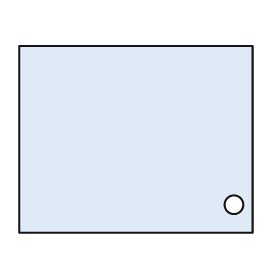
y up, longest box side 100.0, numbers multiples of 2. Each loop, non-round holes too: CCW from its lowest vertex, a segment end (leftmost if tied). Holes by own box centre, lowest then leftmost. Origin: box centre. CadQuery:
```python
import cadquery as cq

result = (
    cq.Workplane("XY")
    .moveTo(-50.0, -40.0)
    .lineTo(50.0, -40.0)
    .lineTo(50.0, 40.0)
    .lineTo(-50.0, 40.0)
    .close()
    .moveTo(42.0, -28.0)
    .circle(4.0)
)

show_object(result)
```